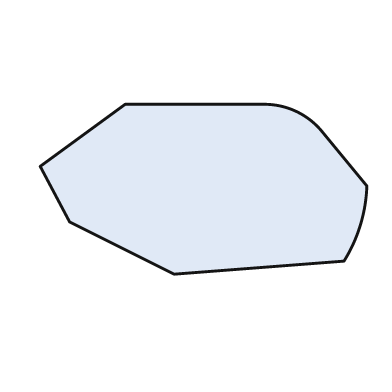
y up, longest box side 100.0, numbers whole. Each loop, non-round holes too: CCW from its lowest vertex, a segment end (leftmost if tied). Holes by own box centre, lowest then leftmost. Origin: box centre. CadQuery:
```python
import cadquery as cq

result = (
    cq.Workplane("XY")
    .moveTo(-9.0, -26.0)
    .lineTo(43.0, -22.0)
    .threePointArc((48.0, -11.0), (50.0, 1.0))
    .lineTo(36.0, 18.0)
    .threePointArc((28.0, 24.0), (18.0, 26.0))
    .lineTo(-24.0, 26.0)
    .lineTo(-50.0, 7.0)
    .lineTo(-41.0, -10.0)
    .close()
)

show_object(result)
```